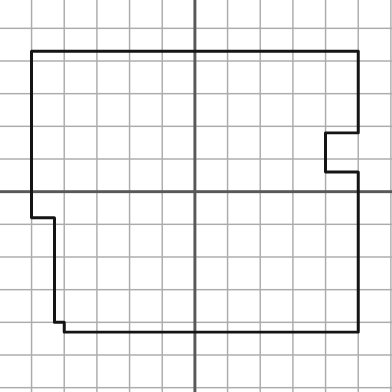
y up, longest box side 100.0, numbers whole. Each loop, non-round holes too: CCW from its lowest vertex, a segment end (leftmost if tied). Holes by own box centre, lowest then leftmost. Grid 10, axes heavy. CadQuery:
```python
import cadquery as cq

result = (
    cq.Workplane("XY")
    .moveTo(-40.0, -43.0)
    .lineTo(50.0, -43.0)
    .lineTo(50.0, 6.0)
    .lineTo(40.0, 6.0)
    .lineTo(40.0, 18.0)
    .lineTo(50.0, 18.0)
    .lineTo(50.0, 43.0)
    .lineTo(-50.0, 43.0)
    .lineTo(-50.0, -8.0)
    .lineTo(-43.0, -8.0)
    .lineTo(-43.0, -40.0)
    .lineTo(-40.0, -40.0)
    .close()
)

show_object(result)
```